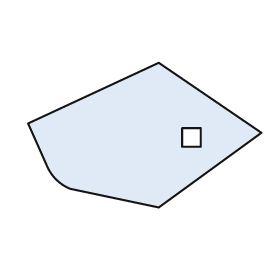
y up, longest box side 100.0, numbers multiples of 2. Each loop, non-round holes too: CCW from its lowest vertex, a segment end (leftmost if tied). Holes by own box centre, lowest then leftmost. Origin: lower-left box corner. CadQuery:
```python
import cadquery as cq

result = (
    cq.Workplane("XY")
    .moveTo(56.0, 0.0)
    .lineTo(100.0, 32.0)
    .lineTo(56.0, 62.0)
    .lineTo(0.0, 36.0)
    .lineTo(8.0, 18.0)
    .threePointArc((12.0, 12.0), (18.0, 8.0))
    .close()
    .moveTo(66.0, 26.0)
    .lineTo(74.0, 26.0)
    .lineTo(74.0, 34.0)
    .lineTo(66.0, 34.0)
    .close()
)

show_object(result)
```